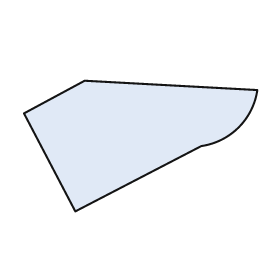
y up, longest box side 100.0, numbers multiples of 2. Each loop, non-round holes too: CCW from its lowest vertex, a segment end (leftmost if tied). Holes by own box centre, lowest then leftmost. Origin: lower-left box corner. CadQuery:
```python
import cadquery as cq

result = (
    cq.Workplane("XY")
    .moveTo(22.0, 0.0)
    .lineTo(76.0, 28.0)
    .threePointArc((92.0, 36.0), (100.0, 52.0))
    .lineTo(26.0, 56.0)
    .lineTo(0.0, 42.0)
    .close()
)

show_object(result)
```